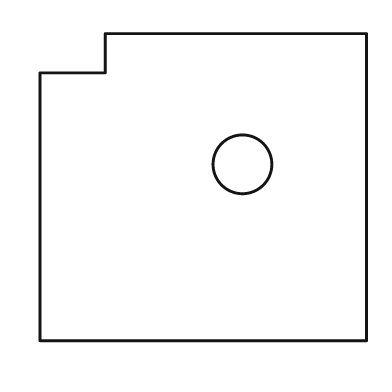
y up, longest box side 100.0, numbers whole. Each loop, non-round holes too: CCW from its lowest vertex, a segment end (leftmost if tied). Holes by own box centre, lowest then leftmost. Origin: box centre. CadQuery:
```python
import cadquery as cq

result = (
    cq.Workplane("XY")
    .moveTo(-50.0, -47.0)
    .lineTo(50.0, -47.0)
    .lineTo(50.0, 47.0)
    .lineTo(-30.0, 47.0)
    .lineTo(-30.0, 35.0)
    .lineTo(-50.0, 35.0)
    .close()
    .moveTo(12.0, 7.0)
    .circle(9.0)
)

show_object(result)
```